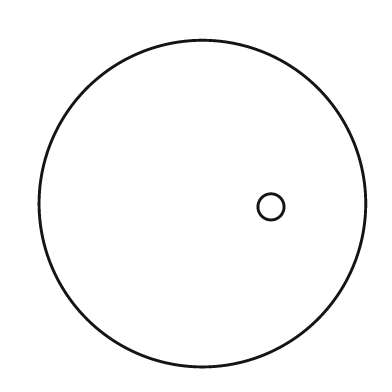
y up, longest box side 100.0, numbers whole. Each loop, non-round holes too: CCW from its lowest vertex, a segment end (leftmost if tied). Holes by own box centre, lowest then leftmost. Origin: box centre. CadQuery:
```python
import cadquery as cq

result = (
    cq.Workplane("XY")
    .moveTo(0.0, 0.0)
    .circle(50.0)
    .moveTo(21.0, -1.0)
    .circle(4.0)
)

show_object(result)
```